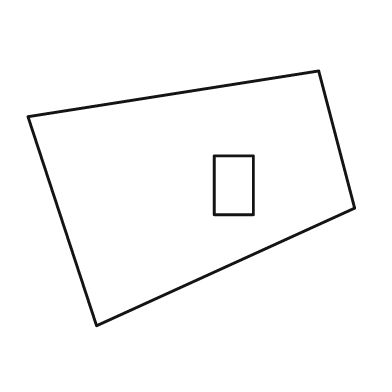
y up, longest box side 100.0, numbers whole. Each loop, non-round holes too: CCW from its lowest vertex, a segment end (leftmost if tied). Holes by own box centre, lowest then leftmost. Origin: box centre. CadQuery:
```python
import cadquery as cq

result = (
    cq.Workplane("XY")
    .moveTo(-29.0, -39.0)
    .lineTo(50.0, -3.0)
    .lineTo(39.0, 39.0)
    .lineTo(-50.0, 25.0)
    .close()
    .moveTo(7.0, -5.0)
    .lineTo(19.0, -5.0)
    .lineTo(19.0, 13.0)
    .lineTo(7.0, 13.0)
    .close()
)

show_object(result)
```